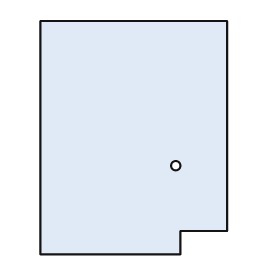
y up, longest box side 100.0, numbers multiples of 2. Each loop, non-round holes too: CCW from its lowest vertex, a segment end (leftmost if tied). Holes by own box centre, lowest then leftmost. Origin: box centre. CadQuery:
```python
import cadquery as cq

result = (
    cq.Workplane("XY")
    .moveTo(-40.0, -50.0)
    .lineTo(20.0, -50.0)
    .lineTo(20.0, -40.0)
    .lineTo(40.0, -40.0)
    .lineTo(40.0, 50.0)
    .lineTo(-40.0, 50.0)
    .close()
    .moveTo(18.0, -12.0)
    .circle(2.0)
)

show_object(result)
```